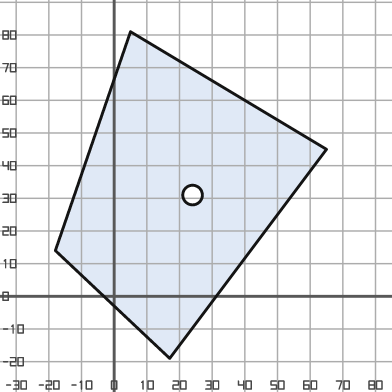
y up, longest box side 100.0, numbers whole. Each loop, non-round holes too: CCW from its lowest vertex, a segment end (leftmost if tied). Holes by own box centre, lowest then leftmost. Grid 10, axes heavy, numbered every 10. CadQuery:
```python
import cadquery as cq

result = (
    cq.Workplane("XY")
    .moveTo(17.0, -19.0)
    .lineTo(65.0, 45.0)
    .lineTo(5.0, 81.0)
    .lineTo(-18.0, 14.0)
    .close()
    .moveTo(24.0, 31.0)
    .circle(3.0)
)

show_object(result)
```